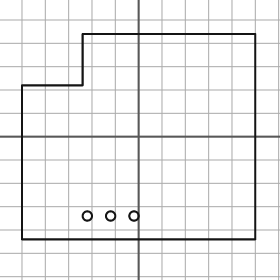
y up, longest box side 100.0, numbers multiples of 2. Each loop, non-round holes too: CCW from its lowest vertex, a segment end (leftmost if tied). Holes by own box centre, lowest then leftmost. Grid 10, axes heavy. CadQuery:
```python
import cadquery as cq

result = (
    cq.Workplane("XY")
    .moveTo(-50.0, -44.0)
    .lineTo(50.0, -44.0)
    .lineTo(50.0, 44.0)
    .lineTo(-24.0, 44.0)
    .lineTo(-24.0, 22.0)
    .lineTo(-50.0, 22.0)
    .close()
    .moveTo(-22.0, -34.0)
    .circle(2.0)
    .moveTo(-12.0, -34.0)
    .circle(2.0)
    .moveTo(-2.0, -34.0)
    .circle(2.0)
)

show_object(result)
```